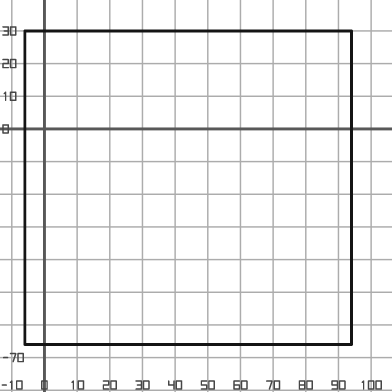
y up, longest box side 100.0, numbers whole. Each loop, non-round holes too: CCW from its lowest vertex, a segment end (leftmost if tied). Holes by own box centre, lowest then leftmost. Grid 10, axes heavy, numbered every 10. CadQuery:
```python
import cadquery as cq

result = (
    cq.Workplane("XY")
    .moveTo(-6.0, -66.0)
    .lineTo(94.0, -66.0)
    .lineTo(94.0, 30.0)
    .lineTo(-6.0, 30.0)
    .close()
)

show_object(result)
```